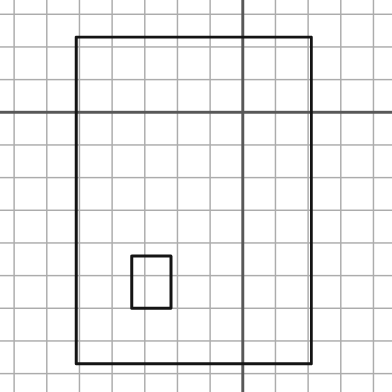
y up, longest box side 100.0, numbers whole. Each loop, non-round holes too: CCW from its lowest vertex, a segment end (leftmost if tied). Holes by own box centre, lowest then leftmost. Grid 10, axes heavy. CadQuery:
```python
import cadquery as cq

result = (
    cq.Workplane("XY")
    .moveTo(-51.0, -77.0)
    .lineTo(21.0, -77.0)
    .lineTo(21.0, 23.0)
    .lineTo(-51.0, 23.0)
    .close()
    .moveTo(-34.0, -60.0)
    .lineTo(-22.0, -60.0)
    .lineTo(-22.0, -44.0)
    .lineTo(-34.0, -44.0)
    .close()
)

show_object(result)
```